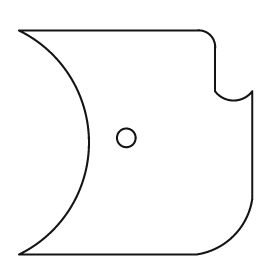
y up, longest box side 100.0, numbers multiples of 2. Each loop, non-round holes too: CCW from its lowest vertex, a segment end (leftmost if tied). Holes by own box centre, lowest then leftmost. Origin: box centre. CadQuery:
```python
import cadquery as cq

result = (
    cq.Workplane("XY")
    .moveTo(-50.0, -48.0)
    .lineTo(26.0, -48.0)
    .threePointArc((42.0, -40.0), (50.0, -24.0))
    .lineTo(50.0, 22.0)
    .threePointArc((42.0, 18.0), (34.0, 22.0))
    .lineTo(34.0, 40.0)
    .threePointArc((32.0, 46.0), (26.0, 48.0))
    .lineTo(-50.0, 48.0)
    .threePointArc((-20.0, 0.0), (-50.0, -48.0))
    .close()
    .moveTo(-4.0, 2.0)
    .circle(4.0)
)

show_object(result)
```